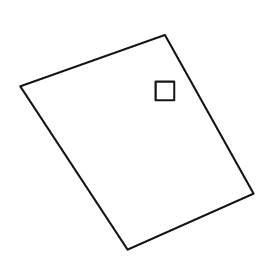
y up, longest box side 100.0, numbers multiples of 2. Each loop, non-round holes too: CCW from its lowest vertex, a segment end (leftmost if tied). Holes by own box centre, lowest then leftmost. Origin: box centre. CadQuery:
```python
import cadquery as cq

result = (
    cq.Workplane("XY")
    .moveTo(-4.0, -46.0)
    .lineTo(50.0, -22.0)
    .lineTo(12.0, 46.0)
    .lineTo(-50.0, 24.0)
    .close()
    .moveTo(8.0, 18.0)
    .lineTo(16.0, 18.0)
    .lineTo(16.0, 26.0)
    .lineTo(8.0, 26.0)
    .close()
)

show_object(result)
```